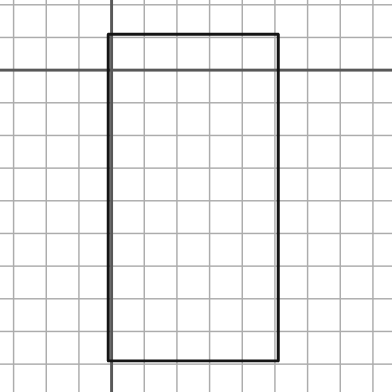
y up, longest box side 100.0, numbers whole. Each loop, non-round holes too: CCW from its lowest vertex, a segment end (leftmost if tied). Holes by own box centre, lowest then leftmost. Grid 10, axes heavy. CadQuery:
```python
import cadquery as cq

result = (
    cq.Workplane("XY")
    .moveTo(-1.0, -89.0)
    .lineTo(51.0, -89.0)
    .lineTo(51.0, 11.0)
    .lineTo(-1.0, 11.0)
    .close()
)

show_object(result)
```